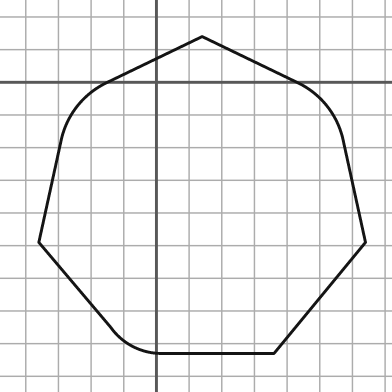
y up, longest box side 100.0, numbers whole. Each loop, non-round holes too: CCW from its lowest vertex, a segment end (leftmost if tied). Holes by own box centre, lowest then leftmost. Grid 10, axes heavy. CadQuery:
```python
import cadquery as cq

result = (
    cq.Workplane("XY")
    .moveTo(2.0, -83.0)
    .lineTo(36.0, -83.0)
    .lineTo(64.0, -49.0)
    .lineTo(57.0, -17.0)
    .threePointArc((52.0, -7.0), (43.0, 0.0))
    .lineTo(14.0, 14.0)
    .lineTo(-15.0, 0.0)
    .threePointArc((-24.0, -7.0), (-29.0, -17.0))
    .lineTo(-36.0, -49.0)
    .lineTo(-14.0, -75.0)
    .threePointArc((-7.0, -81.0), (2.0, -83.0))
    .close()
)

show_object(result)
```